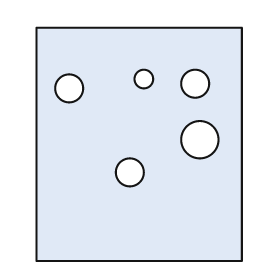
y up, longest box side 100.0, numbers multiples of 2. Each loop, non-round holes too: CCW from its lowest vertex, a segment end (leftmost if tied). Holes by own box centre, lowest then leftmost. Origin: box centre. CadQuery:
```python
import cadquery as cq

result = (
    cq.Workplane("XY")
    .moveTo(-44.0, -50.0)
    .lineTo(44.0, -50.0)
    .lineTo(44.0, 50.0)
    .lineTo(-44.0, 50.0)
    .close()
    .moveTo(-4.0, -12.0)
    .circle(6.0)
    .moveTo(26.0, 2.0)
    .circle(8.0)
    .moveTo(-30.0, 24.0)
    .circle(6.0)
    .moveTo(24.0, 26.0)
    .circle(6.0)
    .moveTo(2.0, 28.0)
    .circle(4.0)
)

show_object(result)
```